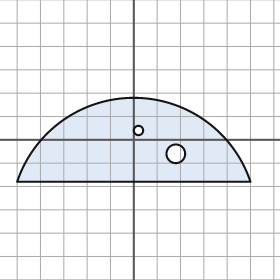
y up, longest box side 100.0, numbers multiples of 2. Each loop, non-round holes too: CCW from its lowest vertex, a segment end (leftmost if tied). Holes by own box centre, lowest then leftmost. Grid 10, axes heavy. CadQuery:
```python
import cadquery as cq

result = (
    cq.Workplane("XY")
    .moveTo(-50.0, -18.0)
    .lineTo(50.0, -18.0)
    .threePointArc((0.0, 18.0), (-50.0, -18.0))
    .close()
    .moveTo(18.0, -6.0)
    .circle(4.0)
    .moveTo(2.0, 4.0)
    .circle(2.0)
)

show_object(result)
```